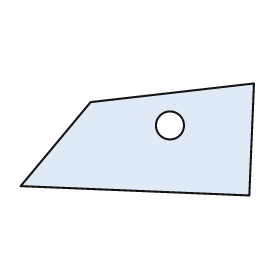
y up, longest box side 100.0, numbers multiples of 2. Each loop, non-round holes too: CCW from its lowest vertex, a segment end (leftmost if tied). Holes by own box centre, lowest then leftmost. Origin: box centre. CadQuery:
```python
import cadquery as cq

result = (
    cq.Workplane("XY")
    .moveTo(48.0, -24.0)
    .lineTo(50.0, 24.0)
    .lineTo(-20.0, 16.0)
    .lineTo(-50.0, -20.0)
    .close()
    .moveTo(14.0, 6.0)
    .circle(6.0)
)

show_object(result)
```